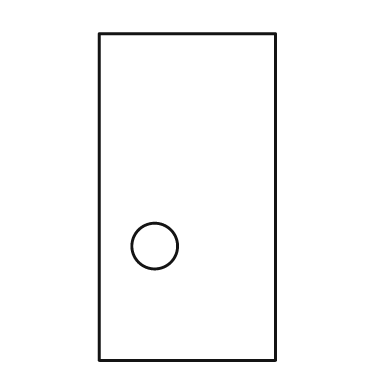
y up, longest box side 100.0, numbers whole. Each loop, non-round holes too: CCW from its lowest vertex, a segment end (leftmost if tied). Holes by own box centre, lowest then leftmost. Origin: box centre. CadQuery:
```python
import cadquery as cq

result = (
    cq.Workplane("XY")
    .moveTo(-27.0, -50.0)
    .lineTo(27.0, -50.0)
    .lineTo(27.0, 50.0)
    .lineTo(-27.0, 50.0)
    .close()
    .moveTo(-10.0, -15.0)
    .circle(7.0)
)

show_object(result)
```